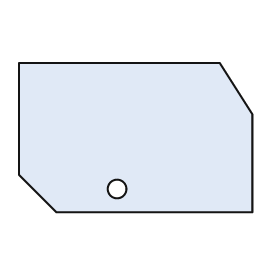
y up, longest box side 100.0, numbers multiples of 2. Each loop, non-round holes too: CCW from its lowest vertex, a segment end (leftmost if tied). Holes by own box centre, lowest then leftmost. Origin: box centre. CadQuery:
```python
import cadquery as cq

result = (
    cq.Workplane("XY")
    .moveTo(-34.0, -32.0)
    .lineTo(50.0, -32.0)
    .lineTo(50.0, 10.0)
    .lineTo(36.0, 32.0)
    .lineTo(-50.0, 32.0)
    .lineTo(-50.0, -16.0)
    .close()
    .moveTo(-8.0, -22.0)
    .circle(4.0)
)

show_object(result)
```